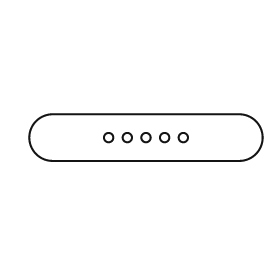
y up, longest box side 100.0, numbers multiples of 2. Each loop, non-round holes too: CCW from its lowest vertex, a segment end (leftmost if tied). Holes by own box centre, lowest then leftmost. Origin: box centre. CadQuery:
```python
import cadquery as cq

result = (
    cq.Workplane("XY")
    .moveTo(-40.0, -10.0)
    .lineTo(40.0, -10.0)
    .threePointArc((50.0, 0.0), (40.0, 10.0))
    .lineTo(-40.0, 10.0)
    .threePointArc((-50.0, 0.0), (-40.0, -10.0))
    .close()
    .moveTo(-16.0, 0.0)
    .circle(2.0)
    .moveTo(-8.0, 0.0)
    .circle(2.0)
    .moveTo(0.0, 0.0)
    .circle(2.0)
    .moveTo(8.0, 0.0)
    .circle(2.0)
    .moveTo(16.0, 0.0)
    .circle(2.0)
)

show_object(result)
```